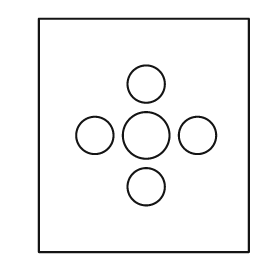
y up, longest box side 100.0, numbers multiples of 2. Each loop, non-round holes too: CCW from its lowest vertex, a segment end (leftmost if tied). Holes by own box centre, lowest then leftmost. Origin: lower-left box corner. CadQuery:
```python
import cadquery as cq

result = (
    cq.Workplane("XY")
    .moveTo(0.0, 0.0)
    .lineTo(90.0, 0.0)
    .lineTo(90.0, 100.0)
    .lineTo(0.0, 100.0)
    .close()
    .moveTo(46.0, 28.0)
    .circle(8.0)
    .moveTo(24.0, 50.0)
    .circle(8.0)
    .moveTo(46.0, 50.0)
    .circle(10.0)
    .moveTo(68.0, 50.0)
    .circle(8.0)
    .moveTo(46.0, 72.0)
    .circle(8.0)
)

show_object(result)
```